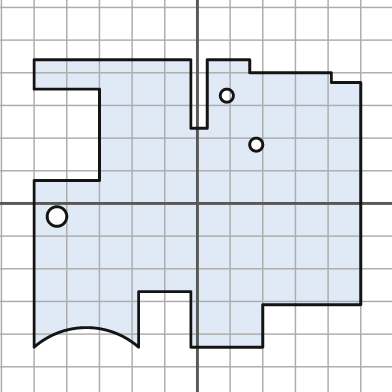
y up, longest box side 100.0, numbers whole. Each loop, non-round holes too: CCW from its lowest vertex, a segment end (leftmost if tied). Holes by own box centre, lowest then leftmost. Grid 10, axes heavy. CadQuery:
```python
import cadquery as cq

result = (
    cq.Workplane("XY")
    .moveTo(-50.0, -44.0)
    .threePointArc((-34.0, -38.0), (-18.0, -44.0))
    .lineTo(-18.0, -27.0)
    .lineTo(-2.0, -27.0)
    .lineTo(-2.0, -44.0)
    .lineTo(20.0, -44.0)
    .lineTo(20.0, -31.0)
    .lineTo(50.0, -31.0)
    .lineTo(50.0, 37.0)
    .lineTo(41.0, 37.0)
    .lineTo(41.0, 40.0)
    .lineTo(16.0, 40.0)
    .lineTo(16.0, 44.0)
    .lineTo(3.0, 44.0)
    .lineTo(3.0, 23.0)
    .lineTo(-2.0, 23.0)
    .lineTo(-2.0, 44.0)
    .lineTo(-50.0, 44.0)
    .lineTo(-50.0, 35.0)
    .lineTo(-30.0, 35.0)
    .lineTo(-30.0, 7.0)
    .lineTo(-50.0, 7.0)
    .close()
    .moveTo(-43.0, -4.0)
    .circle(3.0)
    .moveTo(18.0, 18.0)
    .circle(2.0)
    .moveTo(9.0, 33.0)
    .circle(2.0)
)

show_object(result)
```